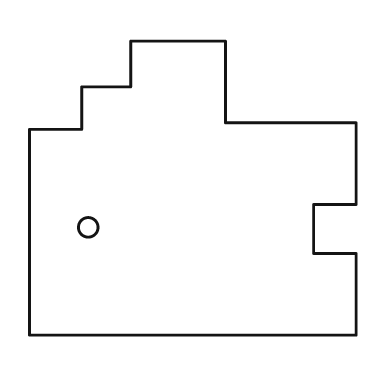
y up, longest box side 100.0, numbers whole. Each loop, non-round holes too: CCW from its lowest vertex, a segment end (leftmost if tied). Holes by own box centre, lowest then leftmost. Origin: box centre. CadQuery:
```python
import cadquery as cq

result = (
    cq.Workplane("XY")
    .moveTo(-50.0, -45.0)
    .lineTo(50.0, -45.0)
    .lineTo(50.0, -20.0)
    .lineTo(37.0, -20.0)
    .lineTo(37.0, -5.0)
    .lineTo(50.0, -5.0)
    .lineTo(50.0, 20.0)
    .lineTo(10.0, 20.0)
    .lineTo(10.0, 45.0)
    .lineTo(-19.0, 45.0)
    .lineTo(-19.0, 31.0)
    .lineTo(-34.0, 31.0)
    .lineTo(-34.0, 18.0)
    .lineTo(-50.0, 18.0)
    .close()
    .moveTo(-32.0, -12.0)
    .circle(3.0)
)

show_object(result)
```